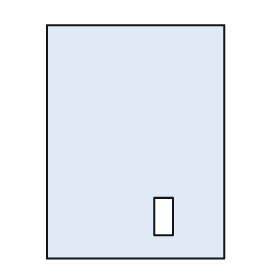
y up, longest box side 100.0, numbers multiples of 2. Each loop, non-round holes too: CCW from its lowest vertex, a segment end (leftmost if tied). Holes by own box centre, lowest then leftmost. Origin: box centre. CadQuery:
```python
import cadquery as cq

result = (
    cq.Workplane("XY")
    .moveTo(-38.0, -50.0)
    .lineTo(38.0, -50.0)
    .lineTo(38.0, 50.0)
    .lineTo(-38.0, 50.0)
    .close()
    .moveTo(8.0, -40.0)
    .lineTo(16.0, -40.0)
    .lineTo(16.0, -24.0)
    .lineTo(8.0, -24.0)
    .close()
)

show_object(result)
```